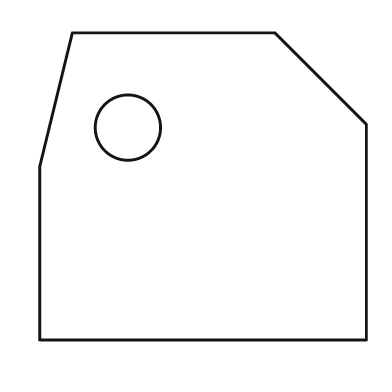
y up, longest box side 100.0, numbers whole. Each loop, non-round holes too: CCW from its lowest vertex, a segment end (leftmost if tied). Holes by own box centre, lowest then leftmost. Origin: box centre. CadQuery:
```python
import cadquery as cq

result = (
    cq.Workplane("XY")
    .moveTo(-50.0, -47.0)
    .lineTo(50.0, -47.0)
    .lineTo(50.0, 19.0)
    .lineTo(22.0, 47.0)
    .lineTo(-40.0, 47.0)
    .lineTo(-50.0, 6.0)
    .close()
    .moveTo(-23.0, 18.0)
    .circle(10.0)
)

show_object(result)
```